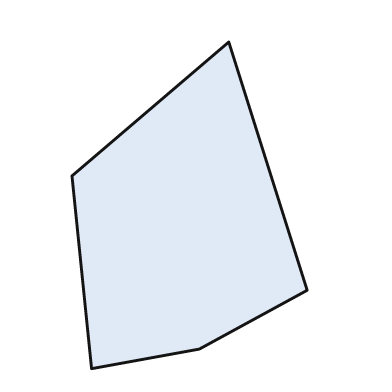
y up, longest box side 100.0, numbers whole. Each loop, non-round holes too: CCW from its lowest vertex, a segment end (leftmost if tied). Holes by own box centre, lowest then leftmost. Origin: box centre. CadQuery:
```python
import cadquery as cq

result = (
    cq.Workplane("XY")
    .moveTo(-30.0, -50.0)
    .lineTo(3.0, -44.0)
    .lineTo(36.0, -26.0)
    .lineTo(12.0, 50.0)
    .lineTo(-36.0, 9.0)
    .close()
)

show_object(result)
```